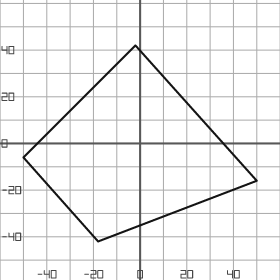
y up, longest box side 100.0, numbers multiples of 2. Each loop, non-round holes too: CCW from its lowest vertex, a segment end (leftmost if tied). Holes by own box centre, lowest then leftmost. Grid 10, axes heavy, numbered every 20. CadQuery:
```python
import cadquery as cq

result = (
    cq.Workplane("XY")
    .moveTo(-18.0, -42.0)
    .lineTo(50.0, -16.0)
    .lineTo(-2.0, 42.0)
    .lineTo(-50.0, -6.0)
    .close()
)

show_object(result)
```